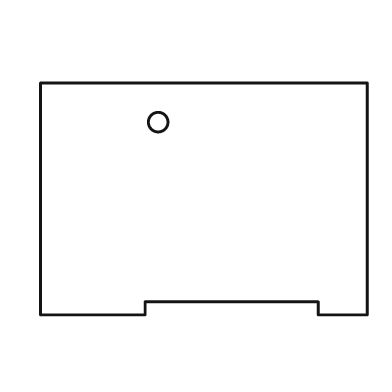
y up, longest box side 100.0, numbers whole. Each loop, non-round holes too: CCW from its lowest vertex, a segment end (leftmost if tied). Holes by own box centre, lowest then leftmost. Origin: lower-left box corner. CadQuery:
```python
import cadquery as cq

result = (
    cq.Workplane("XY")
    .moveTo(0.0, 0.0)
    .lineTo(32.0, 0.0)
    .lineTo(32.0, 4.0)
    .lineTo(85.0, 4.0)
    .lineTo(85.0, 0.0)
    .lineTo(100.0, 0.0)
    .lineTo(100.0, 71.0)
    .lineTo(0.0, 71.0)
    .close()
    .moveTo(36.0, 59.0)
    .circle(3.0)
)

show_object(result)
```